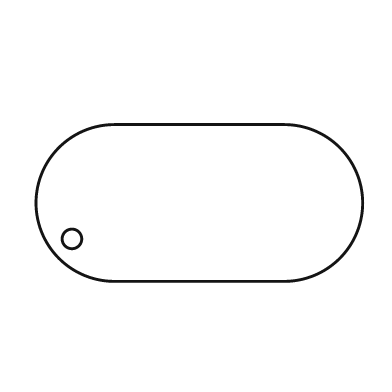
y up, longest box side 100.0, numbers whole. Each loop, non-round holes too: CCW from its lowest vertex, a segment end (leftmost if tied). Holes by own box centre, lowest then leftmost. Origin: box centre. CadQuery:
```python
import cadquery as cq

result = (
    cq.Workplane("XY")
    .moveTo(-26.0, -24.0)
    .lineTo(26.0, -24.0)
    .threePointArc((50.0, 0.0), (26.0, 24.0))
    .lineTo(-26.0, 24.0)
    .threePointArc((-50.0, 0.0), (-26.0, -24.0))
    .close()
    .moveTo(-39.0, -11.0)
    .circle(3.0)
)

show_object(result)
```